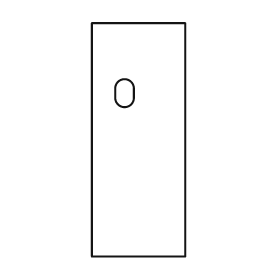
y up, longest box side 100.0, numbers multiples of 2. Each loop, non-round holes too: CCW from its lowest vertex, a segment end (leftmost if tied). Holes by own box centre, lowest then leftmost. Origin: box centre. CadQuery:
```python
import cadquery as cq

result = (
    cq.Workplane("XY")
    .moveTo(-20.0, -50.0)
    .lineTo(20.0, -50.0)
    .lineTo(20.0, 50.0)
    .lineTo(-20.0, 50.0)
    .close()
    .moveTo(-10.0, 18.0)
    .threePointArc((-6.0, 14.0), (-2.0, 18.0))
    .lineTo(-2.0, 22.0)
    .threePointArc((-6.0, 26.0), (-10.0, 22.0))
    .close()
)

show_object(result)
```